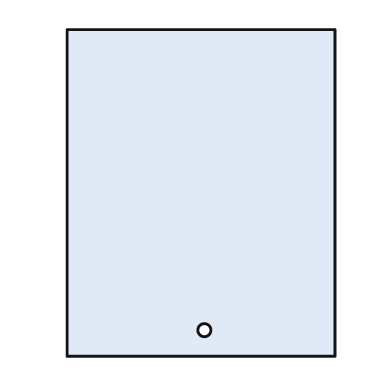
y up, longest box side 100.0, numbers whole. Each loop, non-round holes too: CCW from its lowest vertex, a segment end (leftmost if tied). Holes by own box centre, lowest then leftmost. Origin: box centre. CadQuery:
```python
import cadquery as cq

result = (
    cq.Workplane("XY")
    .moveTo(-41.0, -50.0)
    .lineTo(41.0, -50.0)
    .lineTo(41.0, 50.0)
    .lineTo(-41.0, 50.0)
    .close()
    .moveTo(1.0, -42.0)
    .circle(2.0)
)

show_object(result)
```